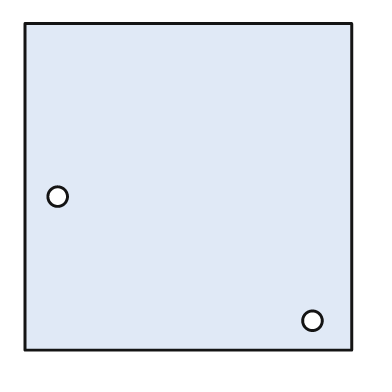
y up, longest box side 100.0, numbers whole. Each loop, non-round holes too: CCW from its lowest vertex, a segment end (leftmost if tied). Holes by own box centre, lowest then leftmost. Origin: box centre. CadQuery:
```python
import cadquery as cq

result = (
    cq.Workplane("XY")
    .moveTo(-50.0, -50.0)
    .lineTo(50.0, -50.0)
    .lineTo(50.0, 50.0)
    .lineTo(-50.0, 50.0)
    .close()
    .moveTo(38.0, -41.0)
    .circle(3.0)
    .moveTo(-40.0, -3.0)
    .circle(3.0)
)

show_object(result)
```